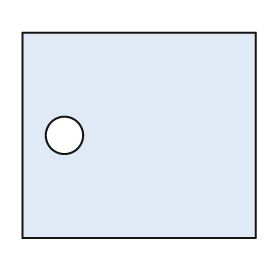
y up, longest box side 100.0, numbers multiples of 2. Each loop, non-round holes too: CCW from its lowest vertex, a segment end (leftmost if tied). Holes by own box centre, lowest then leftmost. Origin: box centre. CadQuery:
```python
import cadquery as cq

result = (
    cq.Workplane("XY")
    .moveTo(-50.0, -44.0)
    .lineTo(50.0, -44.0)
    .lineTo(50.0, 44.0)
    .lineTo(-50.0, 44.0)
    .close()
    .moveTo(-32.0, 0.0)
    .circle(8.0)
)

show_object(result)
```